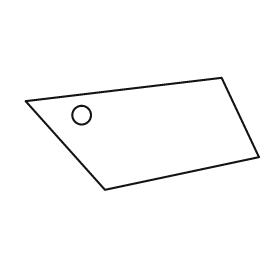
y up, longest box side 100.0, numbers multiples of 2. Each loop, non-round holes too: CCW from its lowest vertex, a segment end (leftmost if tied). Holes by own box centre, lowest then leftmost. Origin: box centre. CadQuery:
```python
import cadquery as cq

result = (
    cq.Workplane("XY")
    .moveTo(-16.0, -24.0)
    .lineTo(50.0, -10.0)
    .lineTo(34.0, 24.0)
    .lineTo(-50.0, 14.0)
    .close()
    .moveTo(-26.0, 8.0)
    .circle(4.0)
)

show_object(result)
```